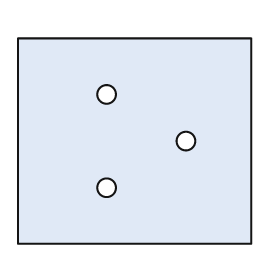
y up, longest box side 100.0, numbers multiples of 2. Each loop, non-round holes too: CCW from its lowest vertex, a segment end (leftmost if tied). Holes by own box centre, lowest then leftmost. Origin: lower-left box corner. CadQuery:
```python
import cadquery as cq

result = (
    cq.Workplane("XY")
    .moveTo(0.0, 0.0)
    .lineTo(100.0, 0.0)
    .lineTo(100.0, 88.0)
    .lineTo(0.0, 88.0)
    .close()
    .moveTo(38.0, 24.0)
    .circle(4.0)
    .moveTo(72.0, 44.0)
    .circle(4.0)
    .moveTo(38.0, 64.0)
    .circle(4.0)
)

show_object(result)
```